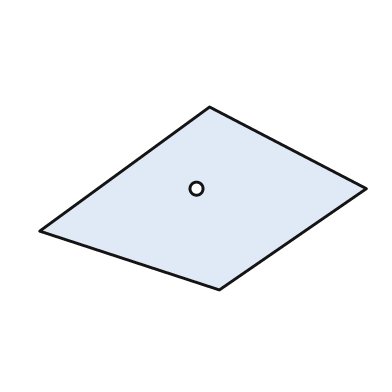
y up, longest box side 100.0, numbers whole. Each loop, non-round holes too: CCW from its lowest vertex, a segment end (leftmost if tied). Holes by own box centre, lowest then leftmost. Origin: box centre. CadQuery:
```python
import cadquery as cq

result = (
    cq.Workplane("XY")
    .moveTo(5.0, -28.0)
    .lineTo(50.0, 3.0)
    .lineTo(2.0, 28.0)
    .lineTo(-50.0, -10.0)
    .close()
    .moveTo(-2.0, 3.0)
    .circle(2.0)
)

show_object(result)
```